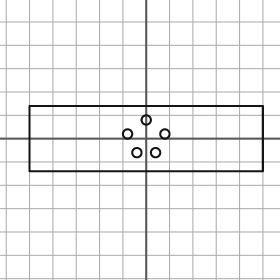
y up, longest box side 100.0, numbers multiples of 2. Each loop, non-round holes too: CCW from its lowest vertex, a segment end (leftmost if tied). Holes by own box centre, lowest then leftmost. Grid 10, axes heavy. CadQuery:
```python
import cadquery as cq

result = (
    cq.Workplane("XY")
    .moveTo(-50.0, -14.0)
    .lineTo(50.0, -14.0)
    .lineTo(50.0, 14.0)
    .lineTo(-50.0, 14.0)
    .close()
    .moveTo(-4.0, -6.0)
    .circle(2.0)
    .moveTo(4.0, -6.0)
    .circle(2.0)
    .moveTo(-8.0, 2.0)
    .circle(2.0)
    .moveTo(8.0, 2.0)
    .circle(2.0)
    .moveTo(0.0, 8.0)
    .circle(2.0)
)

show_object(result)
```